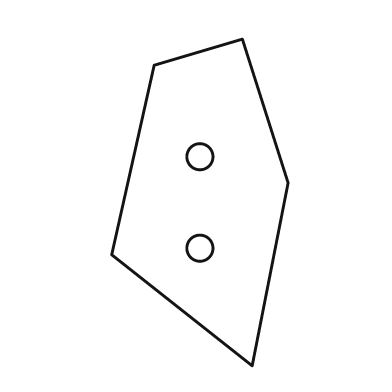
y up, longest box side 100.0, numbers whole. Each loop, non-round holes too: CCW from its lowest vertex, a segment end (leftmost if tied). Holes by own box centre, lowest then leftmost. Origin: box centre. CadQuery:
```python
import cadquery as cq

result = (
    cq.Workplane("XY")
    .moveTo(16.0, -50.0)
    .lineTo(27.0, 6.0)
    .lineTo(13.0, 50.0)
    .lineTo(-14.0, 42.0)
    .lineTo(-27.0, -16.0)
    .close()
    .moveTo(0.0, -14.0)
    .circle(4.0)
    .moveTo(0.0, 14.0)
    .circle(4.0)
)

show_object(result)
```